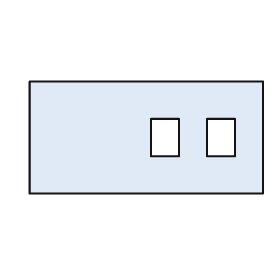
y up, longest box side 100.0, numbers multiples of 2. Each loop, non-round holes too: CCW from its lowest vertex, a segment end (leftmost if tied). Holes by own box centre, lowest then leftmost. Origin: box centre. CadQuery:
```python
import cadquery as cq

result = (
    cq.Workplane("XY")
    .moveTo(-50.0, -24.0)
    .lineTo(50.0, -24.0)
    .lineTo(50.0, 24.0)
    .lineTo(-50.0, 24.0)
    .close()
    .moveTo(2.0, -8.0)
    .lineTo(14.0, -8.0)
    .lineTo(14.0, 8.0)
    .lineTo(2.0, 8.0)
    .close()
    .moveTo(26.0, -8.0)
    .lineTo(38.0, -8.0)
    .lineTo(38.0, 8.0)
    .lineTo(26.0, 8.0)
    .close()
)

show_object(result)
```